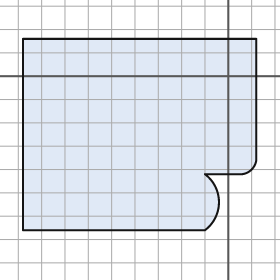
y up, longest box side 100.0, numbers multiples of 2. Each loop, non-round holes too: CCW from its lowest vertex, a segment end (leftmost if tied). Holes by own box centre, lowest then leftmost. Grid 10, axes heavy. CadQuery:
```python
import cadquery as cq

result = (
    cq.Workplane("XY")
    .moveTo(-88.0, -66.0)
    .lineTo(-10.0, -66.0)
    .threePointArc((-4.0, -54.0), (-10.0, -42.0))
    .lineTo(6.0, -42.0)
    .threePointArc((10.0, -40.0), (12.0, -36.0))
    .lineTo(12.0, 16.0)
    .lineTo(-88.0, 16.0)
    .close()
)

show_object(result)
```